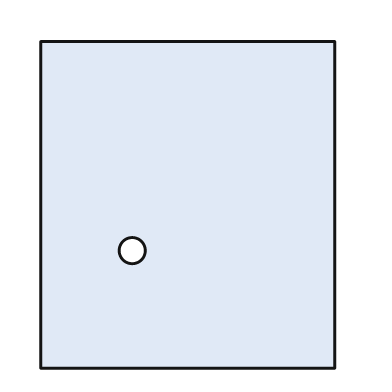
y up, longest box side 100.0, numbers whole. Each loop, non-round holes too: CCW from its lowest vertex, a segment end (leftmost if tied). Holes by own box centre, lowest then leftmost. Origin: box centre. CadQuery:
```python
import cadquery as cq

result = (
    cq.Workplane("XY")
    .moveTo(-45.0, -50.0)
    .lineTo(45.0, -50.0)
    .lineTo(45.0, 50.0)
    .lineTo(-45.0, 50.0)
    .close()
    .moveTo(-17.0, -14.0)
    .circle(4.0)
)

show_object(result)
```